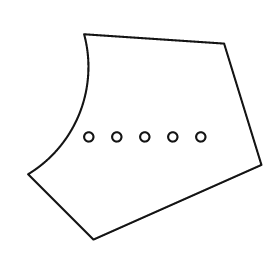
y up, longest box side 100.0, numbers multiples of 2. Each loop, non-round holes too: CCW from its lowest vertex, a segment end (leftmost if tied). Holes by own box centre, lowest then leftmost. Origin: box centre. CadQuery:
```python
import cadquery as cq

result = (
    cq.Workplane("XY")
    .moveTo(-22.0, -44.0)
    .lineTo(50.0, -12.0)
    .lineTo(34.0, 40.0)
    .lineTo(-26.0, 44.0)
    .threePointArc((-28.0, 10.0), (-50.0, -16.0))
    .close()
    .moveTo(-24.0, 0.0)
    .circle(2.0)
    .moveTo(-12.0, 0.0)
    .circle(2.0)
    .moveTo(0.0, 0.0)
    .circle(2.0)
    .moveTo(12.0, 0.0)
    .circle(2.0)
    .moveTo(24.0, 0.0)
    .circle(2.0)
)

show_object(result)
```